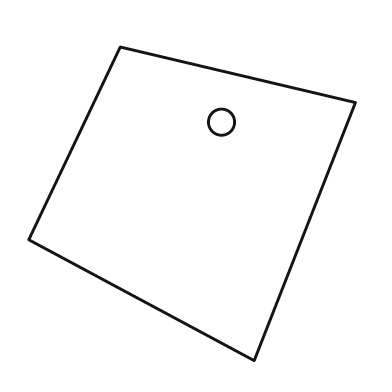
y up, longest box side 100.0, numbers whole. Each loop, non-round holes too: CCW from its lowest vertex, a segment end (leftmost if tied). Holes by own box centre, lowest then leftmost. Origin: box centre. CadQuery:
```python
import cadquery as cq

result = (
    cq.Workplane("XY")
    .moveTo(19.0, -48.0)
    .lineTo(50.0, 31.0)
    .lineTo(-22.0, 48.0)
    .lineTo(-50.0, -11.0)
    .close()
    .moveTo(9.0, 25.0)
    .circle(4.0)
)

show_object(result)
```